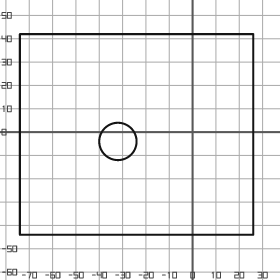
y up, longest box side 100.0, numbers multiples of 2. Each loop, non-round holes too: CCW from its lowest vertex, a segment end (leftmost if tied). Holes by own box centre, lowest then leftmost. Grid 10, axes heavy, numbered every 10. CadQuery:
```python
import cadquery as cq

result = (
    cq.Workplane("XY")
    .moveTo(-74.0, -44.0)
    .lineTo(26.0, -44.0)
    .lineTo(26.0, 42.0)
    .lineTo(-74.0, 42.0)
    .close()
    .moveTo(-32.0, -4.0)
    .circle(8.0)
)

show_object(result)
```